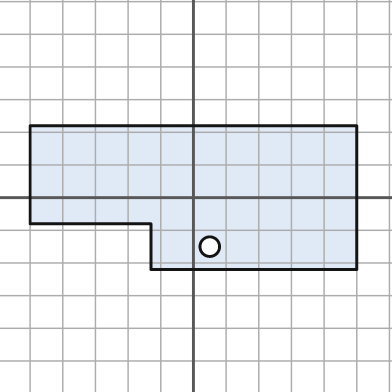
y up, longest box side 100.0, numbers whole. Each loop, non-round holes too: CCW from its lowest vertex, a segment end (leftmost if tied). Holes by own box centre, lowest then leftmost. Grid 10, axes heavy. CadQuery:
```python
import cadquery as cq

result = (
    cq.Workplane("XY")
    .moveTo(-13.0, -22.0)
    .lineTo(50.0, -22.0)
    .lineTo(50.0, 22.0)
    .lineTo(-50.0, 22.0)
    .lineTo(-50.0, -8.0)
    .lineTo(-13.0, -8.0)
    .close()
    .moveTo(5.0, -15.0)
    .circle(3.0)
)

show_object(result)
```